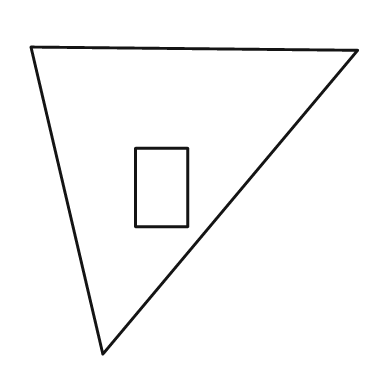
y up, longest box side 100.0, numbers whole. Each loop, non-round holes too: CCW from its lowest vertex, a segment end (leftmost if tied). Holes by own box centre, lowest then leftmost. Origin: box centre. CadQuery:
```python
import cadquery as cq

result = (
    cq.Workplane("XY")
    .moveTo(-28.0, -47.0)
    .lineTo(50.0, 46.0)
    .lineTo(-50.0, 47.0)
    .close()
    .moveTo(-18.0, -8.0)
    .lineTo(-2.0, -8.0)
    .lineTo(-2.0, 16.0)
    .lineTo(-18.0, 16.0)
    .close()
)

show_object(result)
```